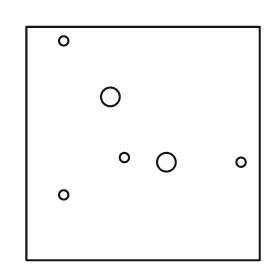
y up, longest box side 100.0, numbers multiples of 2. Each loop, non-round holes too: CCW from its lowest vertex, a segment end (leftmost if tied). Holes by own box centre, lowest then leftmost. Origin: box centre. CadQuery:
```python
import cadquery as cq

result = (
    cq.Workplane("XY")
    .moveTo(-50.0, -50.0)
    .lineTo(50.0, -50.0)
    .lineTo(50.0, 50.0)
    .lineTo(-50.0, 50.0)
    .close()
    .moveTo(-34.0, -22.0)
    .circle(2.0)
    .moveTo(10.0, -8.0)
    .circle(4.0)
    .moveTo(42.0, -8.0)
    .circle(2.0)
    .moveTo(-8.0, -6.0)
    .circle(2.0)
    .moveTo(-14.0, 20.0)
    .circle(4.0)
    .moveTo(-34.0, 44.0)
    .circle(2.0)
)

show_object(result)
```